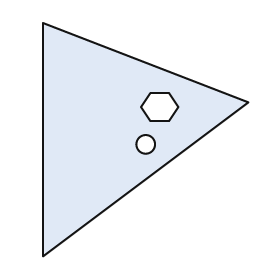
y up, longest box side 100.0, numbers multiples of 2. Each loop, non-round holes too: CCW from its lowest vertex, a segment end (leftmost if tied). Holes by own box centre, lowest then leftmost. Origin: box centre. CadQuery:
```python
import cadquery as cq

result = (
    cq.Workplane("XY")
    .moveTo(-44.0, -50.0)
    .lineTo(44.0, 16.0)
    .lineTo(-44.0, 50.0)
    .close()
    .moveTo(0.0, -2.0)
    .circle(4.0)
    .moveTo(2.0, 8.0)
    .lineTo(10.0, 8.0)
    .lineTo(14.0, 14.0)
    .lineTo(10.0, 20.0)
    .lineTo(2.0, 20.0)
    .lineTo(-2.0, 14.0)
    .close()
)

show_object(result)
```